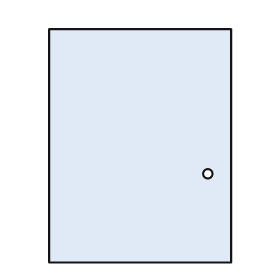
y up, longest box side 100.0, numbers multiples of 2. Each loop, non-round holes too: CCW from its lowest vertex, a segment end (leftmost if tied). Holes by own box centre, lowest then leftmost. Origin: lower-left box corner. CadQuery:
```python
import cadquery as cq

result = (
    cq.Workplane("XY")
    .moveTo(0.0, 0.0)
    .lineTo(78.0, 0.0)
    .lineTo(78.0, 100.0)
    .lineTo(0.0, 100.0)
    .close()
    .moveTo(68.0, 38.0)
    .circle(2.0)
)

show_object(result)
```